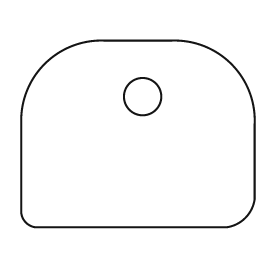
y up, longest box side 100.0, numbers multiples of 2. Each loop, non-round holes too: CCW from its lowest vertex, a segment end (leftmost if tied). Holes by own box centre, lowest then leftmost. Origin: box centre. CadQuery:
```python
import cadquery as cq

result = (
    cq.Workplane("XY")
    .moveTo(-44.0, -40.0)
    .lineTo(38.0, -40.0)
    .threePointArc((46.0, -36.0), (50.0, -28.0))
    .lineTo(50.0, 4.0)
    .threePointArc((40.0, 30.0), (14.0, 40.0))
    .lineTo(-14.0, 40.0)
    .threePointArc((-40.0, 30.0), (-50.0, 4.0))
    .lineTo(-50.0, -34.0)
    .threePointArc((-48.0, -38.0), (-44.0, -40.0))
    .close()
    .moveTo(2.0, 16.0)
    .circle(8.0)
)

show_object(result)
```